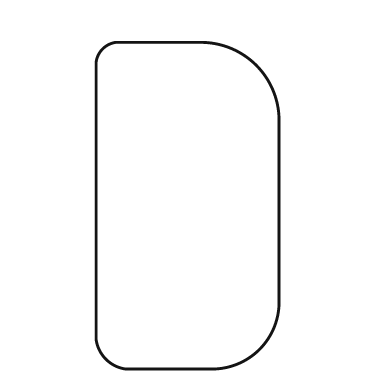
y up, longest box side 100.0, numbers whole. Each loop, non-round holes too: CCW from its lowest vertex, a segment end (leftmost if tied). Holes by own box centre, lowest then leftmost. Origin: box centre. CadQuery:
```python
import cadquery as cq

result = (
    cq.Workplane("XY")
    .moveTo(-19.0, -50.0)
    .lineTo(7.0, -50.0)
    .threePointArc((22.0, -44.0), (28.0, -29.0))
    .lineTo(28.0, 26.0)
    .threePointArc((21.0, 43.0), (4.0, 50.0))
    .lineTo(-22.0, 50.0)
    .threePointArc((-26.0, 48.0), (-28.0, 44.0))
    .lineTo(-28.0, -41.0)
    .threePointArc((-25.0, -47.0), (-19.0, -50.0))
    .close()
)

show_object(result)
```